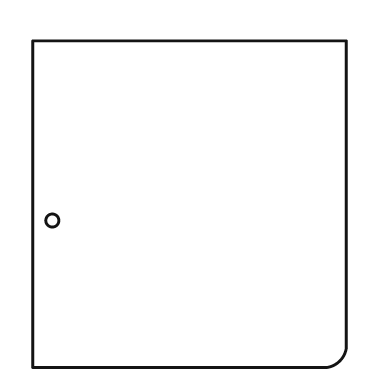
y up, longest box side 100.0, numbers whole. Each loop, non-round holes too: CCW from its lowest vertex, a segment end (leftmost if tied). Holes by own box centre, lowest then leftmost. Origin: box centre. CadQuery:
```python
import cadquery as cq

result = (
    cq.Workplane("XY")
    .moveTo(-48.0, -50.0)
    .lineTo(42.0, -50.0)
    .threePointArc((46.0, -48.0), (48.0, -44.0))
    .lineTo(48.0, 50.0)
    .lineTo(-48.0, 50.0)
    .close()
    .moveTo(-42.0, -5.0)
    .circle(2.0)
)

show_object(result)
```